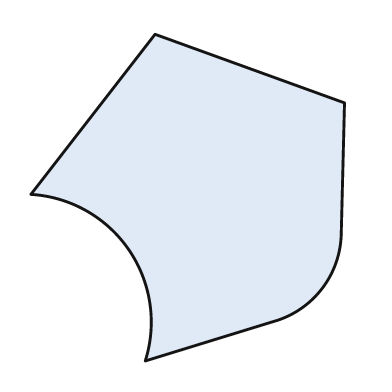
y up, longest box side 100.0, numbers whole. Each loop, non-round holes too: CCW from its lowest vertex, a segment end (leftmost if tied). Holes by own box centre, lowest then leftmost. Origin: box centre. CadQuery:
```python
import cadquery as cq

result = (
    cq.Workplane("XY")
    .moveTo(-13.0, -50.0)
    .lineTo(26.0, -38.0)
    .threePointArc((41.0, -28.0), (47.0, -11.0))
    .lineTo(48.0, 29.0)
    .lineTo(-10.0, 50.0)
    .lineTo(-48.0, 1.0)
    .threePointArc((-18.0, -16.0), (-13.0, -50.0))
    .close()
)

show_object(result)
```